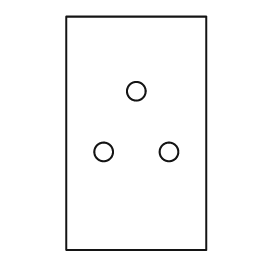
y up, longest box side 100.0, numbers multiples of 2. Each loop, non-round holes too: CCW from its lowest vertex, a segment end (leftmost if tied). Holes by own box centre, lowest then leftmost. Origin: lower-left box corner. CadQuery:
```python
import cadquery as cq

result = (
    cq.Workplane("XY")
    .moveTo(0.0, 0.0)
    .lineTo(60.0, 0.0)
    .lineTo(60.0, 100.0)
    .lineTo(0.0, 100.0)
    .close()
    .moveTo(16.0, 42.0)
    .circle(4.0)
    .moveTo(44.0, 42.0)
    .circle(4.0)
    .moveTo(30.0, 68.0)
    .circle(4.0)
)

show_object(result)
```